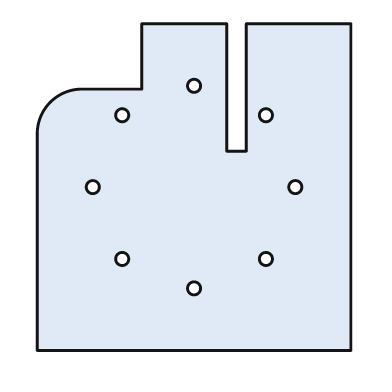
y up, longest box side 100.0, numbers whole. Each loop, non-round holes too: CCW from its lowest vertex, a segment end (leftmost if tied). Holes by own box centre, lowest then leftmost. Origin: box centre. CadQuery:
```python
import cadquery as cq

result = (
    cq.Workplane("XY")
    .moveTo(-48.0, -50.0)
    .lineTo(48.0, -50.0)
    .lineTo(48.0, 50.0)
    .lineTo(16.0, 50.0)
    .lineTo(16.0, 11.0)
    .lineTo(10.0, 11.0)
    .lineTo(10.0, 50.0)
    .lineTo(-16.0, 50.0)
    .lineTo(-16.0, 30.0)
    .lineTo(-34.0, 30.0)
    .threePointArc((-44.0, 26.0), (-48.0, 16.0))
    .close()
    .moveTo(0.0, -31.0)
    .circle(2.0)
    .moveTo(-22.0, -22.0)
    .circle(2.0)
    .moveTo(22.0, -22.0)
    .circle(2.0)
    .moveTo(-31.0, 0.0)
    .circle(2.0)
    .moveTo(31.0, 0.0)
    .circle(2.0)
    .moveTo(-22.0, 22.0)
    .circle(2.0)
    .moveTo(22.0, 22.0)
    .circle(2.0)
    .moveTo(0.0, 31.0)
    .circle(2.0)
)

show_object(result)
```